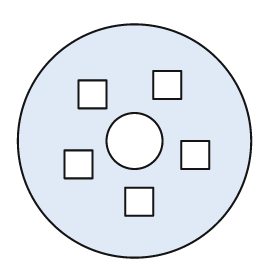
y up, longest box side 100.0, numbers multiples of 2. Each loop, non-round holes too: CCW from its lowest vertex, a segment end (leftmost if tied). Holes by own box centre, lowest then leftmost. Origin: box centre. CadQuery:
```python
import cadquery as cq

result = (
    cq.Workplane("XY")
    .moveTo(0.0, 0.0)
    .circle(50.0)
    .moveTo(-4.0, -32.0)
    .lineTo(8.0, -32.0)
    .lineTo(8.0, -20.0)
    .lineTo(-4.0, -20.0)
    .close()
    .moveTo(-30.0, -16.0)
    .lineTo(-18.0, -16.0)
    .lineTo(-18.0, -4.0)
    .lineTo(-30.0, -4.0)
    .close()
    .moveTo(20.0, -12.0)
    .lineTo(32.0, -12.0)
    .lineTo(32.0, 0.0)
    .lineTo(20.0, 0.0)
    .close()
    .moveTo(0.0, 0.0)
    .circle(12.0)
    .moveTo(-24.0, 14.0)
    .lineTo(-12.0, 14.0)
    .lineTo(-12.0, 26.0)
    .lineTo(-24.0, 26.0)
    .close()
    .moveTo(8.0, 18.0)
    .lineTo(20.0, 18.0)
    .lineTo(20.0, 30.0)
    .lineTo(8.0, 30.0)
    .close()
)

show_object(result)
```